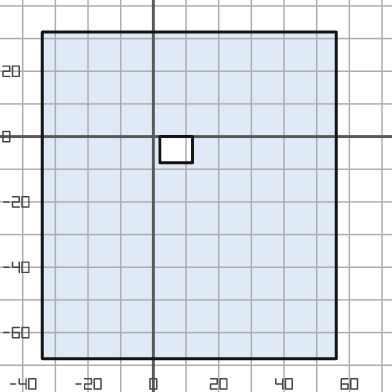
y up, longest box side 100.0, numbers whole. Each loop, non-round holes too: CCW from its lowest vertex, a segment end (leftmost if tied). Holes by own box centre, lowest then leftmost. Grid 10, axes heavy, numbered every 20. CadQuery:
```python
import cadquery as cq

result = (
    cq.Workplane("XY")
    .moveTo(-34.0, -68.0)
    .lineTo(56.0, -68.0)
    .lineTo(56.0, 32.0)
    .lineTo(-34.0, 32.0)
    .close()
    .moveTo(2.0, -8.0)
    .lineTo(12.0, -8.0)
    .lineTo(12.0, 0.0)
    .lineTo(2.0, 0.0)
    .close()
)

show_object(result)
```